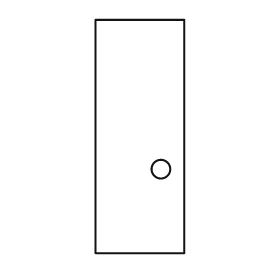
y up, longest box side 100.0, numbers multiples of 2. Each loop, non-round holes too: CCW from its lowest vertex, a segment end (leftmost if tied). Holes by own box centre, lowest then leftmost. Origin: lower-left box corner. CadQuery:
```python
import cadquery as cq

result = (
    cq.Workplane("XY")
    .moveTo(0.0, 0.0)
    .lineTo(38.0, 0.0)
    .lineTo(38.0, 100.0)
    .lineTo(0.0, 100.0)
    .close()
    .moveTo(28.0, 36.0)
    .circle(4.0)
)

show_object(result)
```